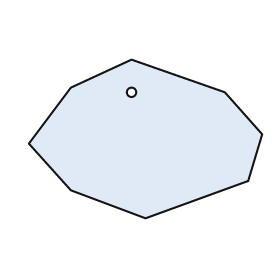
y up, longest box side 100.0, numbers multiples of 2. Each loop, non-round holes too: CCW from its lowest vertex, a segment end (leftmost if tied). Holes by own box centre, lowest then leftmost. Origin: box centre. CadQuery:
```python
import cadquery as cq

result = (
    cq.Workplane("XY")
    .moveTo(0.0, -34.0)
    .lineTo(44.0, -18.0)
    .lineTo(50.0, 2.0)
    .lineTo(34.0, 20.0)
    .lineTo(-6.0, 34.0)
    .lineTo(-32.0, 22.0)
    .lineTo(-50.0, -2.0)
    .lineTo(-32.0, -22.0)
    .close()
    .moveTo(-6.0, 20.0)
    .circle(2.0)
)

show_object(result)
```